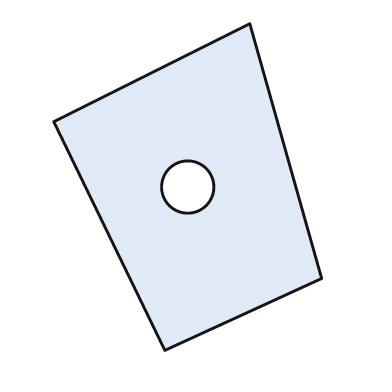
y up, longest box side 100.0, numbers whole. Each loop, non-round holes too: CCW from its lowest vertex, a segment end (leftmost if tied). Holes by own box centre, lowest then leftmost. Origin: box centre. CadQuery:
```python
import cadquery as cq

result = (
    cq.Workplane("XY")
    .moveTo(-7.0, -50.0)
    .lineTo(41.0, -28.0)
    .lineTo(19.0, 50.0)
    .lineTo(-41.0, 20.0)
    .close()
    .moveTo(0.0, 0.0)
    .circle(8.0)
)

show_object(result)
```